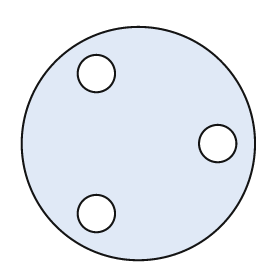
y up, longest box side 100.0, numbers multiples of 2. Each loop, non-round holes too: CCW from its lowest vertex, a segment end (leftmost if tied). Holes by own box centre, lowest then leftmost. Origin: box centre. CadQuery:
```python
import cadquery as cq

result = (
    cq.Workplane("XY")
    .moveTo(0.0, 0.0)
    .circle(50.0)
    .moveTo(-18.0, -30.0)
    .circle(8.0)
    .moveTo(34.0, 0.0)
    .circle(8.0)
    .moveTo(-18.0, 30.0)
    .circle(8.0)
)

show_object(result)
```